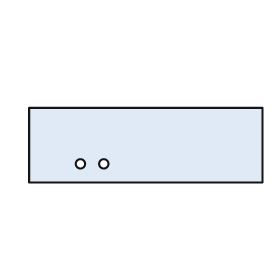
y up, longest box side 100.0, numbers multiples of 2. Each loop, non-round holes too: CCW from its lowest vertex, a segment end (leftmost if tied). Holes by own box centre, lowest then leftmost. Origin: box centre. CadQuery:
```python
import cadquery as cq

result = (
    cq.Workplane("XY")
    .moveTo(-50.0, -16.0)
    .lineTo(50.0, -16.0)
    .lineTo(50.0, 16.0)
    .lineTo(-50.0, 16.0)
    .close()
    .moveTo(-28.0, -8.0)
    .circle(2.0)
    .moveTo(-18.0, -8.0)
    .circle(2.0)
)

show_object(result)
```